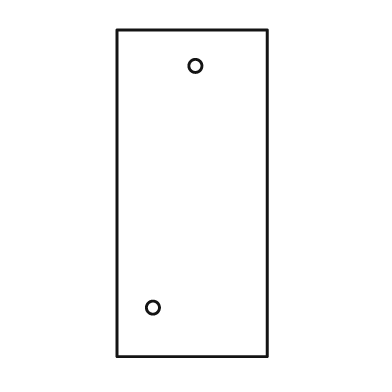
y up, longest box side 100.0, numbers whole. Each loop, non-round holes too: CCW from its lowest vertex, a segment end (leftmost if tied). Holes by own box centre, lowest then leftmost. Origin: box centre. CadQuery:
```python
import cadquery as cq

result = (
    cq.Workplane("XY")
    .moveTo(-23.0, -50.0)
    .lineTo(23.0, -50.0)
    .lineTo(23.0, 50.0)
    .lineTo(-23.0, 50.0)
    .close()
    .moveTo(-12.0, -35.0)
    .circle(2.0)
    .moveTo(1.0, 39.0)
    .circle(2.0)
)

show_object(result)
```